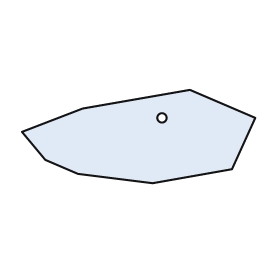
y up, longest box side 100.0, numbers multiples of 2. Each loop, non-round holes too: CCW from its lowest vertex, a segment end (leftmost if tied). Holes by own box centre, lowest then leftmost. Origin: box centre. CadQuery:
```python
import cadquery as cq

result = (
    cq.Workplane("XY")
    .moveTo(6.0, -20.0)
    .lineTo(40.0, -14.0)
    .lineTo(50.0, 8.0)
    .lineTo(22.0, 20.0)
    .lineTo(-24.0, 12.0)
    .lineTo(-50.0, 2.0)
    .lineTo(-40.0, -10.0)
    .lineTo(-26.0, -16.0)
    .close()
    .moveTo(10.0, 8.0)
    .circle(2.0)
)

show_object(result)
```